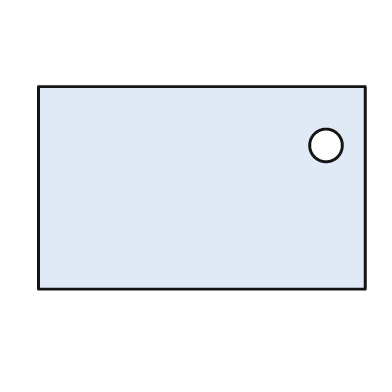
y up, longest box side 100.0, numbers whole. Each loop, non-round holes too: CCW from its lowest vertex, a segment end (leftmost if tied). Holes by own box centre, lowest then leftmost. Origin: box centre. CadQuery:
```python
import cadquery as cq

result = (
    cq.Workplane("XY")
    .moveTo(-50.0, -31.0)
    .lineTo(50.0, -31.0)
    .lineTo(50.0, 31.0)
    .lineTo(-50.0, 31.0)
    .close()
    .moveTo(38.0, 13.0)
    .circle(5.0)
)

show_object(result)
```